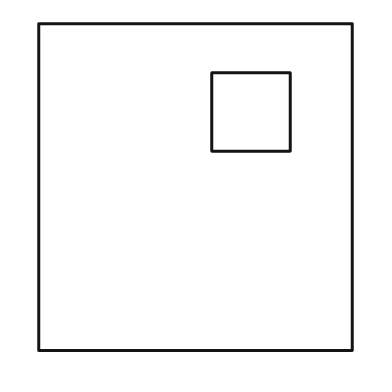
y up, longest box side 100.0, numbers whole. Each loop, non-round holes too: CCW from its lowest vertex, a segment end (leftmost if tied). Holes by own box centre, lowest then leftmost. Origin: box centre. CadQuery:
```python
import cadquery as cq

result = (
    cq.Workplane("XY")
    .moveTo(-48.0, -50.0)
    .lineTo(48.0, -50.0)
    .lineTo(48.0, 50.0)
    .lineTo(-48.0, 50.0)
    .close()
    .moveTo(5.0, 11.0)
    .lineTo(29.0, 11.0)
    .lineTo(29.0, 35.0)
    .lineTo(5.0, 35.0)
    .close()
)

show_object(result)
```